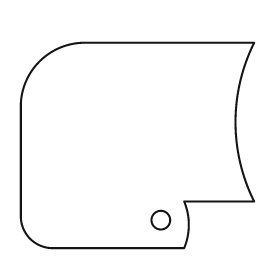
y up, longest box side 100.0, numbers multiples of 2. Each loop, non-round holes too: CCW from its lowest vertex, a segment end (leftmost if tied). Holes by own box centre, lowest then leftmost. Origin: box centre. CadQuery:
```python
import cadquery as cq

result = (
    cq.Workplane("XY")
    .moveTo(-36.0, -44.0)
    .lineTo(20.0, -44.0)
    .threePointArc((22.0, -34.0), (20.0, -24.0))
    .lineTo(50.0, -24.0)
    .threePointArc((42.0, 10.0), (50.0, 44.0))
    .lineTo(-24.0, 44.0)
    .threePointArc((-42.0, 36.0), (-50.0, 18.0))
    .lineTo(-50.0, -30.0)
    .threePointArc((-46.0, -40.0), (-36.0, -44.0))
    .close()
    .moveTo(10.0, -32.0)
    .circle(4.0)
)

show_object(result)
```